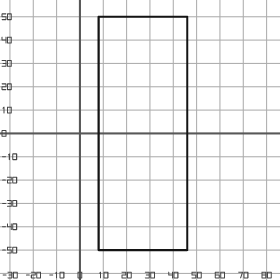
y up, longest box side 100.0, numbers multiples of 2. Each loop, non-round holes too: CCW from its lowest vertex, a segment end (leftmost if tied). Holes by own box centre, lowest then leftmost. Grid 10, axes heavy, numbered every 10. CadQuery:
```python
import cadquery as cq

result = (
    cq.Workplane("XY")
    .moveTo(8.0, -50.0)
    .lineTo(46.0, -50.0)
    .lineTo(46.0, 50.0)
    .lineTo(8.0, 50.0)
    .close()
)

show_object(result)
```